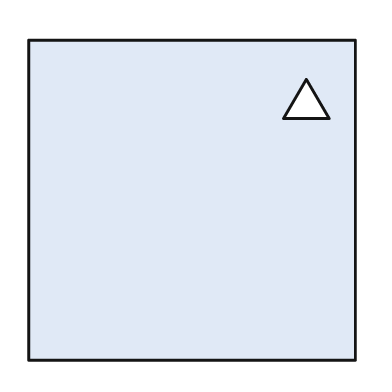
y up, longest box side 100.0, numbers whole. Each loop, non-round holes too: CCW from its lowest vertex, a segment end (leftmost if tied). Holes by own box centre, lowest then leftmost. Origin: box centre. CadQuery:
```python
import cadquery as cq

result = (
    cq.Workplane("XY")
    .moveTo(-50.0, -49.0)
    .lineTo(50.0, -49.0)
    .lineTo(50.0, 49.0)
    .lineTo(-50.0, 49.0)
    .close()
    .moveTo(28.0, 25.0)
    .lineTo(42.0, 25.0)
    .lineTo(35.0, 37.0)
    .close()
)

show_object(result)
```